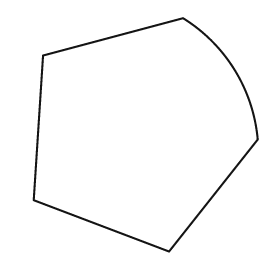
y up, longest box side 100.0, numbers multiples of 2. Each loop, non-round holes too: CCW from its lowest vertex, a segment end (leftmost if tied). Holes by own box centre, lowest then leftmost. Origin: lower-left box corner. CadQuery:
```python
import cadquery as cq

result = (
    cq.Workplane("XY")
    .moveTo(58.0, 0.0)
    .lineTo(96.0, 48.0)
    .threePointArc((86.0, 78.0), (64.0, 100.0))
    .lineTo(4.0, 84.0)
    .lineTo(0.0, 22.0)
    .close()
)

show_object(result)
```